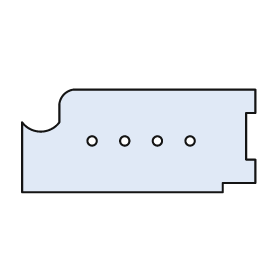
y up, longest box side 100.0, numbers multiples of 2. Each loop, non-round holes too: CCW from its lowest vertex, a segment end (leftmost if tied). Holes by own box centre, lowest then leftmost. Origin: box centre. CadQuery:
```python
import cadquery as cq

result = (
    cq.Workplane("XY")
    .moveTo(-50.0, -22.0)
    .lineTo(36.0, -22.0)
    .lineTo(36.0, -18.0)
    .lineTo(50.0, -18.0)
    .lineTo(50.0, -8.0)
    .lineTo(46.0, -8.0)
    .lineTo(46.0, 12.0)
    .lineTo(50.0, 12.0)
    .lineTo(50.0, 22.0)
    .lineTo(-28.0, 22.0)
    .threePointArc((-32.0, 20.0), (-34.0, 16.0))
    .lineTo(-34.0, 8.0)
    .threePointArc((-42.0, 4.0), (-50.0, 8.0))
    .close()
    .moveTo(-20.0, 0.0)
    .circle(2.0)
    .moveTo(-6.0, 0.0)
    .circle(2.0)
    .moveTo(8.0, 0.0)
    .circle(2.0)
    .moveTo(22.0, 0.0)
    .circle(2.0)
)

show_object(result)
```